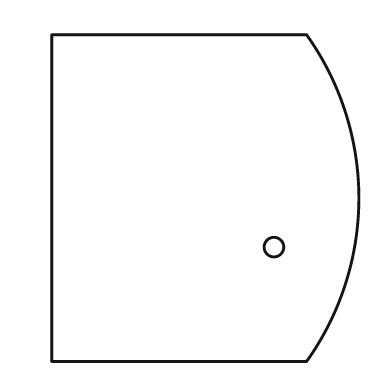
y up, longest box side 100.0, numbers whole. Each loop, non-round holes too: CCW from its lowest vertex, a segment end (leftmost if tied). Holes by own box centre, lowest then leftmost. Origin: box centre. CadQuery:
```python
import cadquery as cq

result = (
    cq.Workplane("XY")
    .moveTo(-47.0, -50.0)
    .lineTo(31.0, -50.0)
    .threePointArc((47.0, 0.0), (31.0, 50.0))
    .lineTo(-47.0, 50.0)
    .close()
    .moveTo(21.0, -15.0)
    .circle(3.0)
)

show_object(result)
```